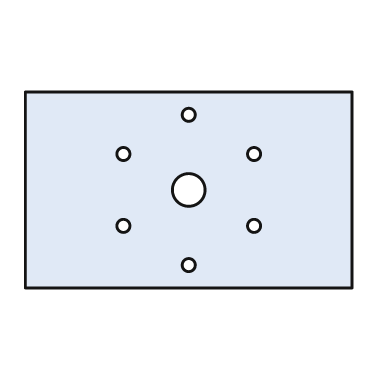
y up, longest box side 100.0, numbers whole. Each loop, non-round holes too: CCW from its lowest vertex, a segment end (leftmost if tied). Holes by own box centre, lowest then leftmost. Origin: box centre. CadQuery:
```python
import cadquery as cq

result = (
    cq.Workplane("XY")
    .moveTo(-50.0, -30.0)
    .lineTo(50.0, -30.0)
    .lineTo(50.0, 30.0)
    .lineTo(-50.0, 30.0)
    .close()
    .moveTo(0.0, -23.0)
    .circle(2.0)
    .moveTo(-20.0, -11.0)
    .circle(2.0)
    .moveTo(20.0, -11.0)
    .circle(2.0)
    .moveTo(0.0, 0.0)
    .circle(5.0)
    .moveTo(-20.0, 11.0)
    .circle(2.0)
    .moveTo(20.0, 11.0)
    .circle(2.0)
    .moveTo(0.0, 23.0)
    .circle(2.0)
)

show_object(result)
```